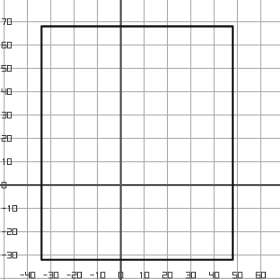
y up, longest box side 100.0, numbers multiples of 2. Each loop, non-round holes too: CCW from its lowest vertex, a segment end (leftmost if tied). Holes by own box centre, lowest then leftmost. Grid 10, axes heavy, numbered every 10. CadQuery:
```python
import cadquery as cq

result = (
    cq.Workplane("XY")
    .moveTo(-34.0, -32.0)
    .lineTo(48.0, -32.0)
    .lineTo(48.0, 68.0)
    .lineTo(-34.0, 68.0)
    .close()
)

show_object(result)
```